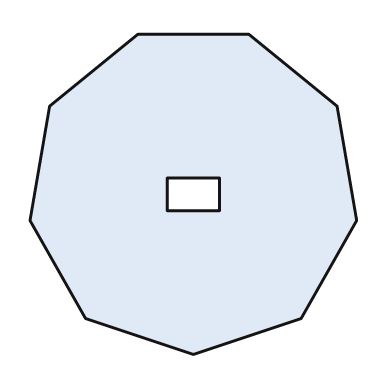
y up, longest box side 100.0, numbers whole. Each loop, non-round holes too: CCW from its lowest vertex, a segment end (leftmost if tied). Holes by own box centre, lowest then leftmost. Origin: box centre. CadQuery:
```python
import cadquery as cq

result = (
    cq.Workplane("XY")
    .moveTo(0.0, -49.0)
    .lineTo(33.0, -38.0)
    .lineTo(50.0, -8.0)
    .lineTo(44.0, 27.0)
    .lineTo(17.0, 49.0)
    .lineTo(-17.0, 49.0)
    .lineTo(-44.0, 27.0)
    .lineTo(-50.0, -8.0)
    .lineTo(-33.0, -38.0)
    .close()
    .moveTo(-8.0, -5.0)
    .lineTo(8.0, -5.0)
    .lineTo(8.0, 5.0)
    .lineTo(-8.0, 5.0)
    .close()
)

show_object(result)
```